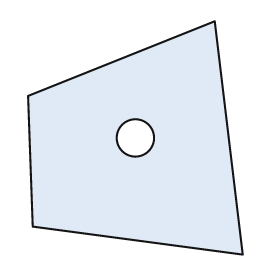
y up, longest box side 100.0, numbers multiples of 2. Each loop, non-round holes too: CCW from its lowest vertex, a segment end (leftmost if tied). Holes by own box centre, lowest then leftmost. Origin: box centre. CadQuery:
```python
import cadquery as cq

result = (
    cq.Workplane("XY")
    .moveTo(46.0, -50.0)
    .lineTo(34.0, 50.0)
    .lineTo(-46.0, 18.0)
    .lineTo(-44.0, -38.0)
    .close()
    .moveTo(0.0, 0.0)
    .circle(8.0)
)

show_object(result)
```